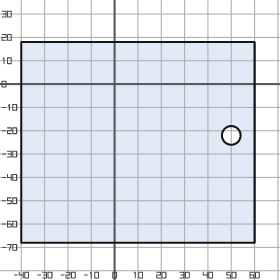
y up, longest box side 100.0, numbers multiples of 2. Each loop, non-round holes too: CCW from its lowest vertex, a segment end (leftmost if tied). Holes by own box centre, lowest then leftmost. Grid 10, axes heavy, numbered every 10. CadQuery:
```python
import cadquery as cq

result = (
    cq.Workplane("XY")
    .moveTo(-40.0, -68.0)
    .lineTo(60.0, -68.0)
    .lineTo(60.0, 18.0)
    .lineTo(-40.0, 18.0)
    .close()
    .moveTo(50.0, -22.0)
    .circle(4.0)
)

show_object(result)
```